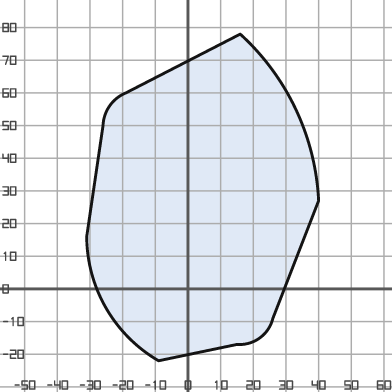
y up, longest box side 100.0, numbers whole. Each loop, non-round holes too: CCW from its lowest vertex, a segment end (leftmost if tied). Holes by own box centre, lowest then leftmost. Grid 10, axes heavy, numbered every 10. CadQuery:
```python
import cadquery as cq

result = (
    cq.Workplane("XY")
    .moveTo(-9.0, -22.0)
    .lineTo(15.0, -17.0)
    .threePointArc((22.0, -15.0), (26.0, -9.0))
    .lineTo(40.0, 27.0)
    .threePointArc((33.0, 55.0), (16.0, 78.0))
    .lineTo(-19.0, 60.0)
    .threePointArc((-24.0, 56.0), (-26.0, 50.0))
    .lineTo(-31.0, 16.0)
    .threePointArc((-25.0, -6.0), (-9.0, -22.0))
    .close()
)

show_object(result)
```